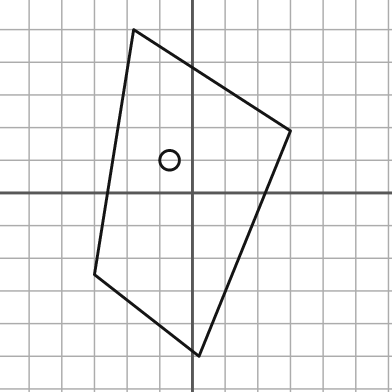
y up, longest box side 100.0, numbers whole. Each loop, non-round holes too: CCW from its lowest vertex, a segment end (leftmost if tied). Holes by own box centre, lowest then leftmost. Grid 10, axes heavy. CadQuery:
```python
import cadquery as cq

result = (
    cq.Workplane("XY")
    .moveTo(2.0, -50.0)
    .lineTo(30.0, 19.0)
    .lineTo(-18.0, 50.0)
    .lineTo(-30.0, -25.0)
    .close()
    .moveTo(-7.0, 10.0)
    .circle(3.0)
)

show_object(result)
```